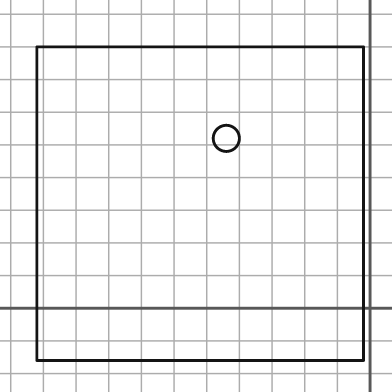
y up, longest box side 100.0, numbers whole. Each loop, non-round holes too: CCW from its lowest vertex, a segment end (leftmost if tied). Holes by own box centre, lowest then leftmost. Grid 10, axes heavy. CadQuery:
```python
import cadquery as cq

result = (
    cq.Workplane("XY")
    .moveTo(-102.0, -16.0)
    .lineTo(-2.0, -16.0)
    .lineTo(-2.0, 80.0)
    .lineTo(-102.0, 80.0)
    .close()
    .moveTo(-44.0, 52.0)
    .circle(4.0)
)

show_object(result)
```